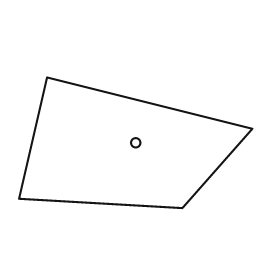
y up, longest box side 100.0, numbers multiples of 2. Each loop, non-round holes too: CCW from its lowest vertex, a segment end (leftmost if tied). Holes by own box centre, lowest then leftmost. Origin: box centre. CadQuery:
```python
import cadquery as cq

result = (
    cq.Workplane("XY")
    .moveTo(20.0, -28.0)
    .lineTo(50.0, 6.0)
    .lineTo(-38.0, 28.0)
    .lineTo(-50.0, -24.0)
    .close()
    .moveTo(0.0, 0.0)
    .circle(2.0)
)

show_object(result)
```